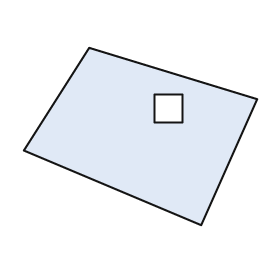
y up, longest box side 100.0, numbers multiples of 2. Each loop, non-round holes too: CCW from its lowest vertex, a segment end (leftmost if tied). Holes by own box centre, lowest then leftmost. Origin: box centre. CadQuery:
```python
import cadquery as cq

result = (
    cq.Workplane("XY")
    .moveTo(26.0, -38.0)
    .lineTo(50.0, 16.0)
    .lineTo(-22.0, 38.0)
    .lineTo(-50.0, -6.0)
    .close()
    .moveTo(6.0, 6.0)
    .lineTo(18.0, 6.0)
    .lineTo(18.0, 18.0)
    .lineTo(6.0, 18.0)
    .close()
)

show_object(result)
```